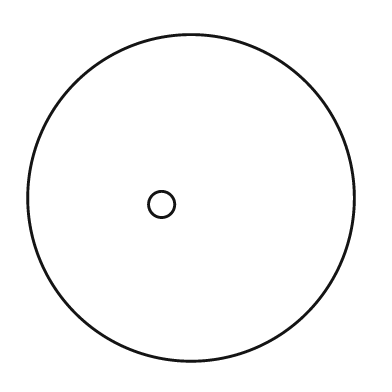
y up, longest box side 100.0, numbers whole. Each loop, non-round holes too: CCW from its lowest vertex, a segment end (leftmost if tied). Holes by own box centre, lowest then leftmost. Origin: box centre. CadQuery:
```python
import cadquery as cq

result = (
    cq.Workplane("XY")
    .moveTo(0.0, 0.0)
    .circle(50.0)
    .moveTo(-9.0, -2.0)
    .circle(4.0)
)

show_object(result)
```